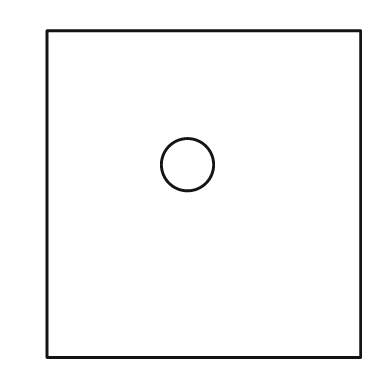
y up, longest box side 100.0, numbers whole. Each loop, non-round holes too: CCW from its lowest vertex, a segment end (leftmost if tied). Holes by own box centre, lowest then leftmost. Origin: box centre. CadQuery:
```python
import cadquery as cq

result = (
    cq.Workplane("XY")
    .moveTo(-48.0, -50.0)
    .lineTo(48.0, -50.0)
    .lineTo(48.0, 50.0)
    .lineTo(-48.0, 50.0)
    .close()
    .moveTo(-5.0, 9.0)
    .circle(8.0)
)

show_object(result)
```